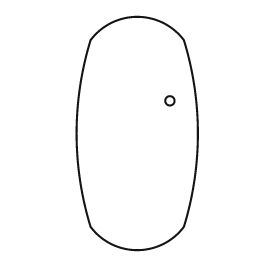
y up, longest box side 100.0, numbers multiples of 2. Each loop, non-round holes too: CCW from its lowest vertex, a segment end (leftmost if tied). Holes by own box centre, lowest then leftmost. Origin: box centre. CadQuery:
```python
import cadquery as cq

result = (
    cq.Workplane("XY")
    .moveTo(-20.0, -40.0)
    .threePointArc((0.0, -50.0), (20.0, -40.0))
    .threePointArc((26.0, 0.0), (20.0, 40.0))
    .threePointArc((0.0, 50.0), (-20.0, 40.0))
    .threePointArc((-26.0, 0.0), (-20.0, -40.0))
    .close()
    .moveTo(14.0, 14.0)
    .circle(2.0)
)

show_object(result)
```